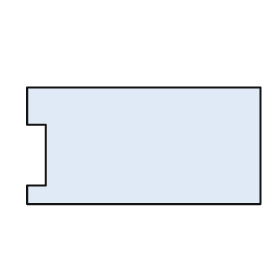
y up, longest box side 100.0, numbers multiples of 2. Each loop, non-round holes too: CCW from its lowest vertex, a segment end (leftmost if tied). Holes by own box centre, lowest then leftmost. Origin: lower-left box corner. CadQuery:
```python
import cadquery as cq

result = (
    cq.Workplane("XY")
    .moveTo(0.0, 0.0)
    .lineTo(100.0, 0.0)
    .lineTo(100.0, 50.0)
    .lineTo(0.0, 50.0)
    .lineTo(0.0, 34.0)
    .lineTo(8.0, 34.0)
    .lineTo(8.0, 8.0)
    .lineTo(0.0, 8.0)
    .close()
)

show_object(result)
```